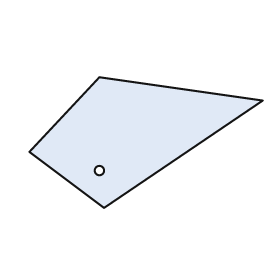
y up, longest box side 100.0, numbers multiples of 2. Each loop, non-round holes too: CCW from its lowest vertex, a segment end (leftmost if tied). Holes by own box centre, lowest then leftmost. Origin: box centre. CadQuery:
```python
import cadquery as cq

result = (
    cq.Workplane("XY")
    .moveTo(-18.0, -28.0)
    .lineTo(50.0, 18.0)
    .lineTo(-20.0, 28.0)
    .lineTo(-50.0, -4.0)
    .close()
    .moveTo(-20.0, -12.0)
    .circle(2.0)
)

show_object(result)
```